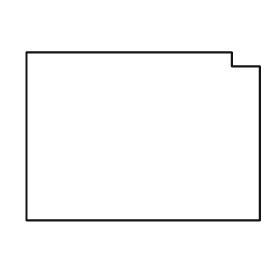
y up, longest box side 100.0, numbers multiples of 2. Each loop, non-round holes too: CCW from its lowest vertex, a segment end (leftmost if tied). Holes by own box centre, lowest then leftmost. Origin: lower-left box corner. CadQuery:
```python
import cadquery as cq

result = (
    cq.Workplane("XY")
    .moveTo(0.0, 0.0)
    .lineTo(100.0, 0.0)
    .lineTo(100.0, 66.0)
    .lineTo(88.0, 66.0)
    .lineTo(88.0, 72.0)
    .lineTo(0.0, 72.0)
    .close()
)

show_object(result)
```